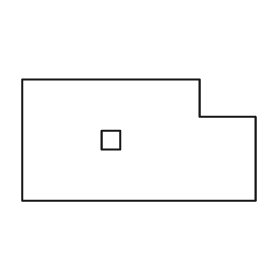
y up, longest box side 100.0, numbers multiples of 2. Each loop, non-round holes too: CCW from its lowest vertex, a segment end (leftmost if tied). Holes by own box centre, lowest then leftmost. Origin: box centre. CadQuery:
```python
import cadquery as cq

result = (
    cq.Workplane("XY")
    .moveTo(-50.0, -26.0)
    .lineTo(50.0, -26.0)
    .lineTo(50.0, 10.0)
    .lineTo(26.0, 10.0)
    .lineTo(26.0, 26.0)
    .lineTo(-50.0, 26.0)
    .close()
    .moveTo(-16.0, -4.0)
    .lineTo(-8.0, -4.0)
    .lineTo(-8.0, 4.0)
    .lineTo(-16.0, 4.0)
    .close()
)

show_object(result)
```